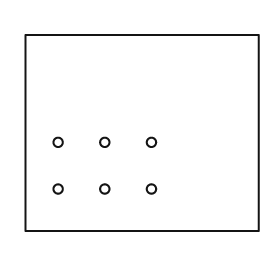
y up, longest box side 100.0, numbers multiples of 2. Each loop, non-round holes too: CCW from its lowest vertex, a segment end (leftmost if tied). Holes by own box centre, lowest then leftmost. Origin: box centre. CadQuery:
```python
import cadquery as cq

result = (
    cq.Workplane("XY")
    .moveTo(-50.0, -42.0)
    .lineTo(50.0, -42.0)
    .lineTo(50.0, 42.0)
    .lineTo(-50.0, 42.0)
    .close()
    .moveTo(-36.0, -24.0)
    .circle(2.0)
    .moveTo(-16.0, -24.0)
    .circle(2.0)
    .moveTo(4.0, -24.0)
    .circle(2.0)
    .moveTo(-36.0, -4.0)
    .circle(2.0)
    .moveTo(-16.0, -4.0)
    .circle(2.0)
    .moveTo(4.0, -4.0)
    .circle(2.0)
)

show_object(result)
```